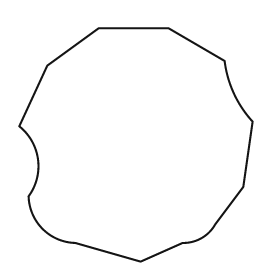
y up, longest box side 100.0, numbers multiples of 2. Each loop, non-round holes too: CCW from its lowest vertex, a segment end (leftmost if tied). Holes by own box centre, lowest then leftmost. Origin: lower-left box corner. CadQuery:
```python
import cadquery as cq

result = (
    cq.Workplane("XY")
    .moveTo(52.0, 0.0)
    .lineTo(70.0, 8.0)
    .threePointArc((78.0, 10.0), (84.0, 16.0))
    .lineTo(96.0, 32.0)
    .lineTo(100.0, 60.0)
    .threePointArc((92.0, 72.0), (88.0, 86.0))
    .lineTo(64.0, 100.0)
    .lineTo(34.0, 100.0)
    .lineTo(12.0, 84.0)
    .lineTo(0.0, 58.0)
    .threePointArc((8.0, 44.0), (4.0, 28.0))
    .threePointArc((10.0, 14.0), (24.0, 8.0))
    .close()
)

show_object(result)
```